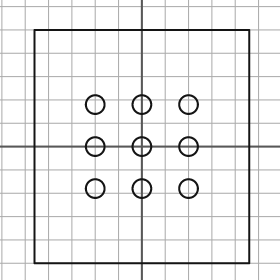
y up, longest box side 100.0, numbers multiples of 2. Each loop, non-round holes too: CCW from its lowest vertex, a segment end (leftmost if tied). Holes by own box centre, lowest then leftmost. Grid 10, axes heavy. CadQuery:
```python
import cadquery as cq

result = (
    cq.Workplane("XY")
    .moveTo(-46.0, -50.0)
    .lineTo(46.0, -50.0)
    .lineTo(46.0, 50.0)
    .lineTo(-46.0, 50.0)
    .close()
    .moveTo(-20.0, -18.0)
    .circle(4.0)
    .moveTo(0.0, -18.0)
    .circle(4.0)
    .moveTo(20.0, -18.0)
    .circle(4.0)
    .moveTo(-20.0, 0.0)
    .circle(4.0)
    .moveTo(0.0, 0.0)
    .circle(4.0)
    .moveTo(20.0, 0.0)
    .circle(4.0)
    .moveTo(-20.0, 18.0)
    .circle(4.0)
    .moveTo(0.0, 18.0)
    .circle(4.0)
    .moveTo(20.0, 18.0)
    .circle(4.0)
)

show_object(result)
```